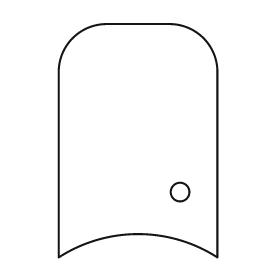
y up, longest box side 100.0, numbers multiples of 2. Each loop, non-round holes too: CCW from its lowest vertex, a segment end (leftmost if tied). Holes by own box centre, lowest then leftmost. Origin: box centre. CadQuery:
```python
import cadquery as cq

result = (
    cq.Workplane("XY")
    .moveTo(-34.0, -50.0)
    .threePointArc((0.0, -40.0), (34.0, -50.0))
    .lineTo(34.0, 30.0)
    .threePointArc((28.0, 44.0), (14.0, 50.0))
    .lineTo(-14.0, 50.0)
    .threePointArc((-28.0, 44.0), (-34.0, 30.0))
    .close()
    .moveTo(18.0, -22.0)
    .circle(4.0)
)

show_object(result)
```